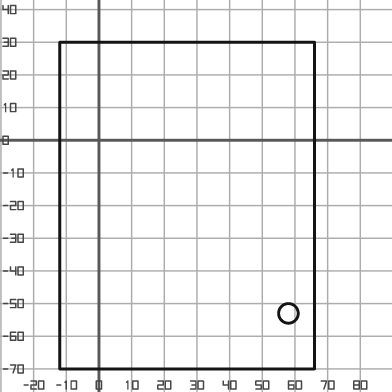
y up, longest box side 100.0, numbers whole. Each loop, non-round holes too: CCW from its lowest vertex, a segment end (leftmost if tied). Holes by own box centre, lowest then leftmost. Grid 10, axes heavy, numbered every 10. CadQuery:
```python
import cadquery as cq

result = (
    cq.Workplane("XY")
    .moveTo(-12.0, -70.0)
    .lineTo(66.0, -70.0)
    .lineTo(66.0, 30.0)
    .lineTo(-12.0, 30.0)
    .close()
    .moveTo(58.0, -53.0)
    .circle(3.0)
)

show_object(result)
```